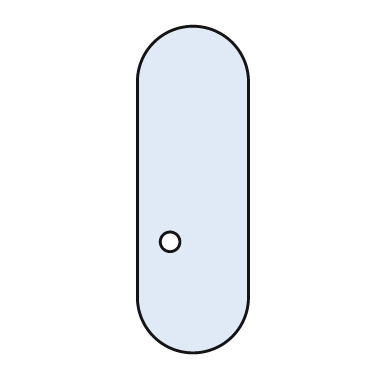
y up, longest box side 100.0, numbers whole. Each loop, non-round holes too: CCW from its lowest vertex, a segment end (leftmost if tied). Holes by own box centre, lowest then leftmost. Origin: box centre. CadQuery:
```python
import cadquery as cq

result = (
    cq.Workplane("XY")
    .moveTo(-17.0, -33.0)
    .threePointArc((0.0, -50.0), (17.0, -33.0))
    .lineTo(17.0, 33.0)
    .threePointArc((0.0, 50.0), (-17.0, 33.0))
    .close()
    .moveTo(-7.0, -16.0)
    .circle(3.0)
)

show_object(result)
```